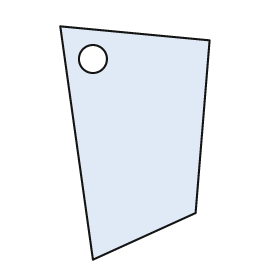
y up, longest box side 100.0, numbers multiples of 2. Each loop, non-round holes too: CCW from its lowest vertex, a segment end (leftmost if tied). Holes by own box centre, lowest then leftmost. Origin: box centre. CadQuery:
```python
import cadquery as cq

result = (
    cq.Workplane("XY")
    .moveTo(-18.0, -50.0)
    .lineTo(26.0, -30.0)
    .lineTo(32.0, 44.0)
    .lineTo(-32.0, 50.0)
    .close()
    .moveTo(-18.0, 36.0)
    .circle(6.0)
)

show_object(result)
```